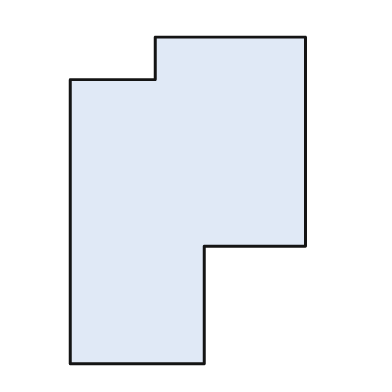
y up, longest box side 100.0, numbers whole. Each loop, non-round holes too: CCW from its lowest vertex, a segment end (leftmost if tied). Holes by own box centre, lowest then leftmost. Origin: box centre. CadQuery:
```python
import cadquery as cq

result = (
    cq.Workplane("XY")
    .moveTo(-36.0, -50.0)
    .lineTo(5.0, -50.0)
    .lineTo(5.0, -14.0)
    .lineTo(36.0, -14.0)
    .lineTo(36.0, 50.0)
    .lineTo(-10.0, 50.0)
    .lineTo(-10.0, 37.0)
    .lineTo(-36.0, 37.0)
    .close()
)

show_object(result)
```